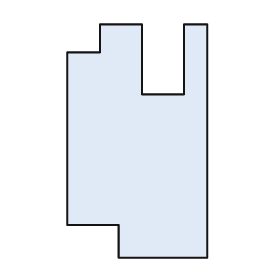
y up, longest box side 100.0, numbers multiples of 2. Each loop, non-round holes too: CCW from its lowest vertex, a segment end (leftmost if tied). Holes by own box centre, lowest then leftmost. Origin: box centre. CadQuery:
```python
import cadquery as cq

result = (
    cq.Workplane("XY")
    .moveTo(-8.0, -50.0)
    .lineTo(30.0, -50.0)
    .lineTo(30.0, 50.0)
    .lineTo(20.0, 50.0)
    .lineTo(20.0, 20.0)
    .lineTo(2.0, 20.0)
    .lineTo(2.0, 50.0)
    .lineTo(-16.0, 50.0)
    .lineTo(-16.0, 38.0)
    .lineTo(-30.0, 38.0)
    .lineTo(-30.0, -36.0)
    .lineTo(-8.0, -36.0)
    .close()
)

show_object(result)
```